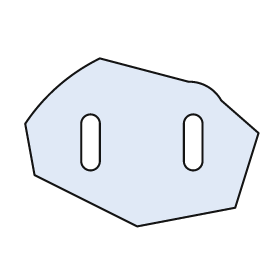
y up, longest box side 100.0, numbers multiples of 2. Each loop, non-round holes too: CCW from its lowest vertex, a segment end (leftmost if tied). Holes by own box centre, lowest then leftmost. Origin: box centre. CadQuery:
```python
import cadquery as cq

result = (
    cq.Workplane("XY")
    .moveTo(-2.0, -36.0)
    .lineTo(40.0, -28.0)
    .lineTo(50.0, 4.0)
    .lineTo(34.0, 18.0)
    .threePointArc((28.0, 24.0), (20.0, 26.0))
    .lineTo(-18.0, 36.0)
    .threePointArc((-36.0, 24.0), (-50.0, 8.0))
    .lineTo(-46.0, -14.0)
    .close()
    .moveTo(-26.0, -8.0)
    .threePointArc((-22.0, -12.0), (-18.0, -8.0))
    .lineTo(-18.0, 8.0)
    .threePointArc((-22.0, 12.0), (-26.0, 8.0))
    .close()
    .moveTo(18.0, -8.0)
    .threePointArc((22.0, -12.0), (26.0, -8.0))
    .lineTo(26.0, 8.0)
    .threePointArc((22.0, 12.0), (18.0, 8.0))
    .close()
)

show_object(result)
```